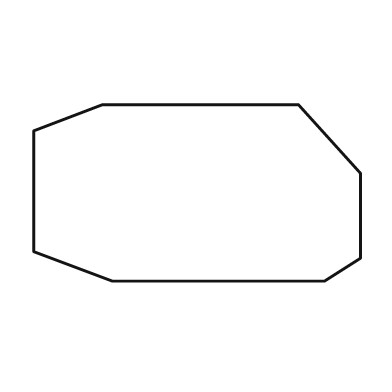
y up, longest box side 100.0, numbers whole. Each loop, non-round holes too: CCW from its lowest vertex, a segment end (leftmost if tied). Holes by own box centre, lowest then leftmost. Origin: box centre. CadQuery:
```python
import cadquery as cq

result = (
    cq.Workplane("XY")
    .moveTo(-26.0, -27.0)
    .lineTo(39.0, -27.0)
    .lineTo(50.0, -20.0)
    .lineTo(50.0, 6.0)
    .lineTo(31.0, 27.0)
    .lineTo(-29.0, 27.0)
    .lineTo(-50.0, 19.0)
    .lineTo(-50.0, -18.0)
    .close()
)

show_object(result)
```